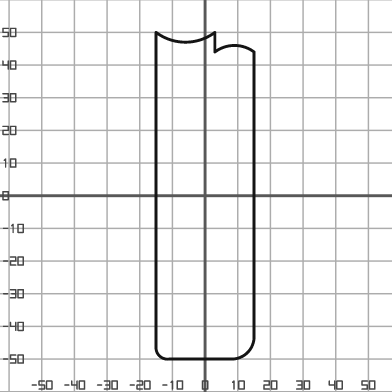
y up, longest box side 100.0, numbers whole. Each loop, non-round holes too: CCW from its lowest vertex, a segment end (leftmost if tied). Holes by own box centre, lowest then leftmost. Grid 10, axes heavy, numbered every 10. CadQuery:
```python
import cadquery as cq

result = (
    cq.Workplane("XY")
    .moveTo(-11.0, -50.0)
    .lineTo(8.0, -50.0)
    .threePointArc((13.0, -48.0), (15.0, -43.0))
    .lineTo(15.0, 44.0)
    .threePointArc((9.0, 46.0), (3.0, 44.0))
    .lineTo(3.0, 50.0)
    .threePointArc((-6.0, 47.0), (-15.0, 50.0))
    .lineTo(-15.0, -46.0)
    .threePointArc((-14.0, -49.0), (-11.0, -50.0))
    .close()
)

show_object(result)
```